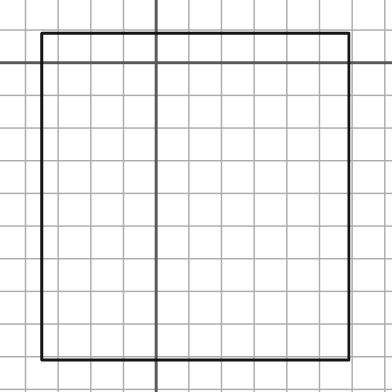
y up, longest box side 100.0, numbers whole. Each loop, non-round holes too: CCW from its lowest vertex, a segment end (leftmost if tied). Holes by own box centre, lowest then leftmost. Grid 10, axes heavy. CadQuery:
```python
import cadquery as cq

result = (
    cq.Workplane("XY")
    .moveTo(-35.0, -91.0)
    .lineTo(59.0, -91.0)
    .lineTo(59.0, 9.0)
    .lineTo(-35.0, 9.0)
    .close()
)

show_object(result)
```